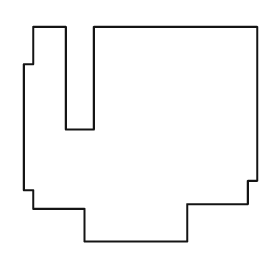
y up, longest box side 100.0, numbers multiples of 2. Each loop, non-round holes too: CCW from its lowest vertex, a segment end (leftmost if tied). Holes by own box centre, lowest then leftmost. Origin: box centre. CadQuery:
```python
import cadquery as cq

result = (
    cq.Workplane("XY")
    .moveTo(-24.0, -46.0)
    .lineTo(20.0, -46.0)
    .lineTo(20.0, -30.0)
    .lineTo(46.0, -30.0)
    .lineTo(46.0, -20.0)
    .lineTo(50.0, -20.0)
    .lineTo(50.0, 46.0)
    .lineTo(-20.0, 46.0)
    .lineTo(-20.0, 2.0)
    .lineTo(-32.0, 2.0)
    .lineTo(-32.0, 46.0)
    .lineTo(-46.0, 46.0)
    .lineTo(-46.0, 30.0)
    .lineTo(-50.0, 30.0)
    .lineTo(-50.0, -24.0)
    .lineTo(-46.0, -24.0)
    .lineTo(-46.0, -32.0)
    .lineTo(-24.0, -32.0)
    .close()
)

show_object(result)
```